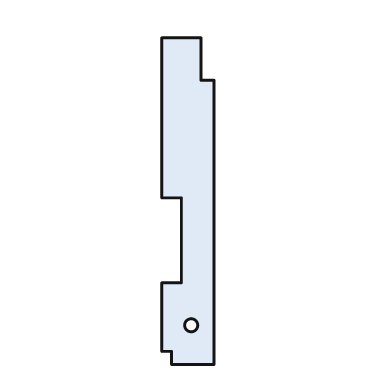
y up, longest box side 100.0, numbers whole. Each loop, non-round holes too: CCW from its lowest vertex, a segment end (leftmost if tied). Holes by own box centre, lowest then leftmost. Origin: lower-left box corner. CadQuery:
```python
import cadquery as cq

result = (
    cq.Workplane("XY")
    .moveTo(3.0, 0.0)
    .lineTo(16.0, 0.0)
    .lineTo(16.0, 87.0)
    .lineTo(12.0, 87.0)
    .lineTo(12.0, 100.0)
    .lineTo(0.0, 100.0)
    .lineTo(0.0, 51.0)
    .lineTo(6.0, 51.0)
    .lineTo(6.0, 25.0)
    .lineTo(0.0, 25.0)
    .lineTo(0.0, 4.0)
    .lineTo(3.0, 4.0)
    .close()
    .moveTo(9.0, 12.0)
    .circle(2.0)
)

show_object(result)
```